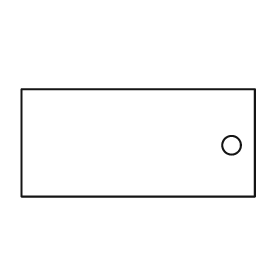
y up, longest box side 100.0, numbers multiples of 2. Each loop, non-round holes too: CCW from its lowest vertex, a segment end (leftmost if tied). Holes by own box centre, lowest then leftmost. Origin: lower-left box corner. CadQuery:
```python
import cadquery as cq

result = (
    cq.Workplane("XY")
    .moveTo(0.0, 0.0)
    .lineTo(100.0, 0.0)
    .lineTo(100.0, 46.0)
    .lineTo(0.0, 46.0)
    .close()
    .moveTo(90.0, 22.0)
    .circle(4.0)
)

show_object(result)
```